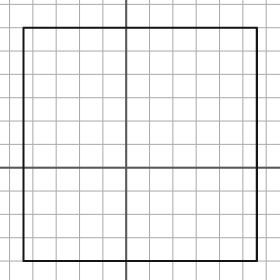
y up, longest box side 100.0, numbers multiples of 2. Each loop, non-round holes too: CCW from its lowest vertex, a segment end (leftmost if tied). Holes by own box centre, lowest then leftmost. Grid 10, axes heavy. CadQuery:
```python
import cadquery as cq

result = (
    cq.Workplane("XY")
    .moveTo(-44.0, -40.0)
    .lineTo(56.0, -40.0)
    .lineTo(56.0, 60.0)
    .lineTo(-44.0, 60.0)
    .close()
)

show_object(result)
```